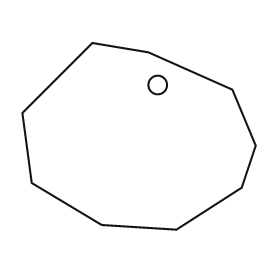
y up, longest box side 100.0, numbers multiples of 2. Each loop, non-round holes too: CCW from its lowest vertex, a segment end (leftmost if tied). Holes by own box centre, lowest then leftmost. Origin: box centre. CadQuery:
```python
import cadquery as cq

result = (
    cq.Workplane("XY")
    .moveTo(16.0, -40.0)
    .lineTo(44.0, -22.0)
    .lineTo(50.0, -4.0)
    .lineTo(40.0, 20.0)
    .lineTo(4.0, 36.0)
    .lineTo(-20.0, 40.0)
    .lineTo(-50.0, 10.0)
    .lineTo(-46.0, -20.0)
    .lineTo(-16.0, -38.0)
    .close()
    .moveTo(8.0, 22.0)
    .circle(4.0)
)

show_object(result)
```